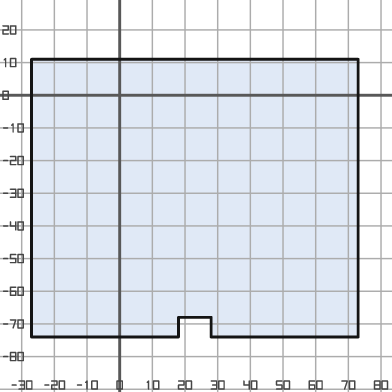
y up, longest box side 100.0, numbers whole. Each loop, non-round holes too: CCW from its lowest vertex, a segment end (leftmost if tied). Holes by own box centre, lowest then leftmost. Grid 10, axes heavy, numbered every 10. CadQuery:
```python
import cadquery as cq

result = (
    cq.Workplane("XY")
    .moveTo(-27.0, -74.0)
    .lineTo(18.0, -74.0)
    .lineTo(18.0, -68.0)
    .lineTo(28.0, -68.0)
    .lineTo(28.0, -74.0)
    .lineTo(73.0, -74.0)
    .lineTo(73.0, 11.0)
    .lineTo(-27.0, 11.0)
    .close()
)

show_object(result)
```